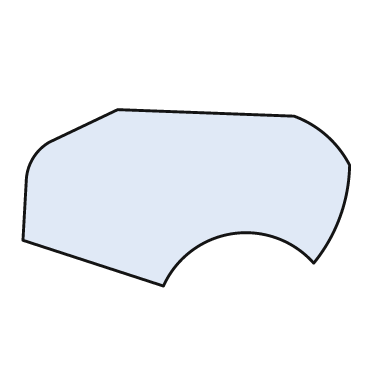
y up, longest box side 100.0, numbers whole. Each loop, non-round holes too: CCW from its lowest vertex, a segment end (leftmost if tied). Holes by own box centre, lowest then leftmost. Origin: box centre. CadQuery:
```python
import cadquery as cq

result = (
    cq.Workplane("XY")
    .moveTo(-7.0, -27.0)
    .threePointArc((14.0, -11.0), (39.0, -20.0))
    .threePointArc((47.0, -6.0), (50.0, 10.0))
    .threePointArc((43.0, 19.0), (33.0, 25.0))
    .lineTo(-21.0, 27.0)
    .lineTo(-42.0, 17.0)
    .threePointArc((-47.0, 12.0), (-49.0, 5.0))
    .lineTo(-50.0, -13.0)
    .close()
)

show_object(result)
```